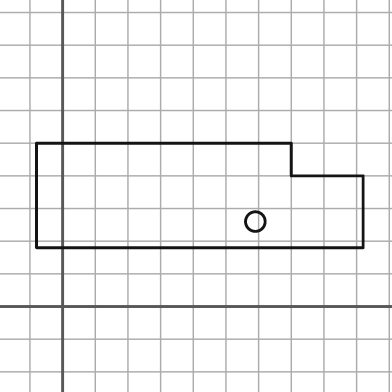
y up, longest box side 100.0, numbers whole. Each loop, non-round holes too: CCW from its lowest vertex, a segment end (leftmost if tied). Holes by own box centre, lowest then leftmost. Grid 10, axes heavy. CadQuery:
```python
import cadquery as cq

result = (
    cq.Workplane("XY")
    .moveTo(-8.0, 18.0)
    .lineTo(92.0, 18.0)
    .lineTo(92.0, 40.0)
    .lineTo(70.0, 40.0)
    .lineTo(70.0, 50.0)
    .lineTo(-8.0, 50.0)
    .close()
    .moveTo(59.0, 26.0)
    .circle(3.0)
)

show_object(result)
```